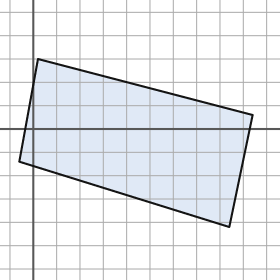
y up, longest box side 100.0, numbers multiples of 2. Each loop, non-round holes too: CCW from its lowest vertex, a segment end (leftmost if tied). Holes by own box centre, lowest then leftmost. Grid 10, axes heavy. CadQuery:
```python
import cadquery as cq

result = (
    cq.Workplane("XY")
    .moveTo(84.0, -42.0)
    .lineTo(94.0, 6.0)
    .lineTo(2.0, 30.0)
    .lineTo(-6.0, -14.0)
    .close()
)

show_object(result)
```